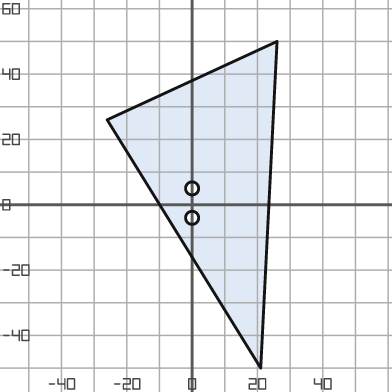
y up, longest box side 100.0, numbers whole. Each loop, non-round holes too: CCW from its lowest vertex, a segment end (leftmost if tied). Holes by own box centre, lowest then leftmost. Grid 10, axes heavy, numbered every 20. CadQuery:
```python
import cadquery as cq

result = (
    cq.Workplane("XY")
    .moveTo(21.0, -50.0)
    .lineTo(26.0, 50.0)
    .lineTo(-26.0, 26.0)
    .close()
    .moveTo(0.0, -4.0)
    .circle(2.0)
    .moveTo(0.0, 5.0)
    .circle(2.0)
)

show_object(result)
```